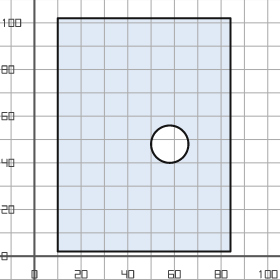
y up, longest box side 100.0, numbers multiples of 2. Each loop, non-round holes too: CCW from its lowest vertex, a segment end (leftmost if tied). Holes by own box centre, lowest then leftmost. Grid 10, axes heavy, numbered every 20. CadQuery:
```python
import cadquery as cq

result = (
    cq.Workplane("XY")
    .moveTo(10.0, 2.0)
    .lineTo(84.0, 2.0)
    .lineTo(84.0, 102.0)
    .lineTo(10.0, 102.0)
    .close()
    .moveTo(58.0, 48.0)
    .circle(8.0)
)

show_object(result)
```